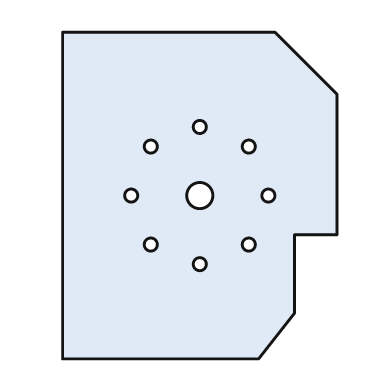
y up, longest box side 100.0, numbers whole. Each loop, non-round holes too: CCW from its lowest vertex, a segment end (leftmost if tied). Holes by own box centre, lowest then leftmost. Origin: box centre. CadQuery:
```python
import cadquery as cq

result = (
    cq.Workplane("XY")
    .moveTo(-42.0, -50.0)
    .lineTo(18.0, -50.0)
    .lineTo(29.0, -36.0)
    .lineTo(29.0, -12.0)
    .lineTo(42.0, -12.0)
    .lineTo(42.0, 31.0)
    .lineTo(23.0, 50.0)
    .lineTo(-42.0, 50.0)
    .close()
    .moveTo(0.0, -21.0)
    .circle(2.0)
    .moveTo(-15.0, -15.0)
    .circle(2.0)
    .moveTo(15.0, -15.0)
    .circle(2.0)
    .moveTo(-21.0, 0.0)
    .circle(2.0)
    .moveTo(0.0, 0.0)
    .circle(4.0)
    .moveTo(21.0, 0.0)
    .circle(2.0)
    .moveTo(-15.0, 15.0)
    .circle(2.0)
    .moveTo(15.0, 15.0)
    .circle(2.0)
    .moveTo(0.0, 21.0)
    .circle(2.0)
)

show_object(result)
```